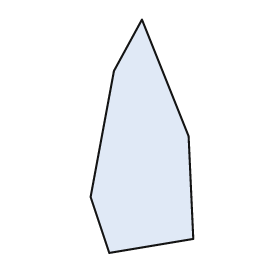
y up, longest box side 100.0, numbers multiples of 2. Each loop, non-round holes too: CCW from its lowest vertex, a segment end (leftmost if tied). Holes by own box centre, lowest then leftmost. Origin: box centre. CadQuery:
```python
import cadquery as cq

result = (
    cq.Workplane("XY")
    .moveTo(-14.0, -50.0)
    .lineTo(22.0, -44.0)
    .lineTo(20.0, 0.0)
    .lineTo(0.0, 50.0)
    .lineTo(-12.0, 28.0)
    .lineTo(-22.0, -26.0)
    .close()
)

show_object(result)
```